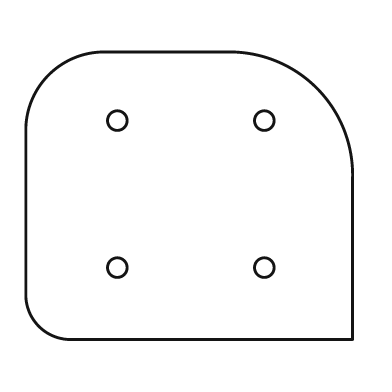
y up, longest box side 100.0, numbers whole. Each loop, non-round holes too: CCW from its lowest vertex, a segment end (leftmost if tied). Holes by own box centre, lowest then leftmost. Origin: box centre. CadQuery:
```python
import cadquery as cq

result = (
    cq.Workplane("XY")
    .moveTo(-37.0, -44.0)
    .lineTo(50.0, -44.0)
    .lineTo(50.0, 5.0)
    .threePointArc((39.0, 33.0), (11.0, 44.0))
    .lineTo(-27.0, 44.0)
    .threePointArc((-43.0, 37.0), (-50.0, 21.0))
    .lineTo(-50.0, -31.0)
    .threePointArc((-46.0, -40.0), (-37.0, -44.0))
    .close()
    .moveTo(-22.0, -22.0)
    .circle(3.0)
    .moveTo(23.0, -22.0)
    .circle(3.0)
    .moveTo(-22.0, 23.0)
    .circle(3.0)
    .moveTo(23.0, 23.0)
    .circle(3.0)
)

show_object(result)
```